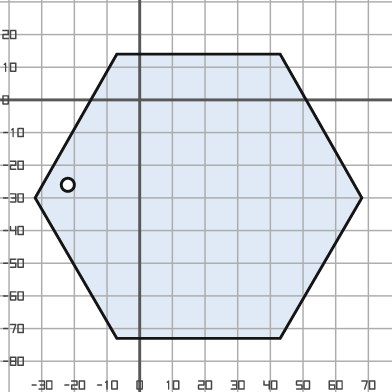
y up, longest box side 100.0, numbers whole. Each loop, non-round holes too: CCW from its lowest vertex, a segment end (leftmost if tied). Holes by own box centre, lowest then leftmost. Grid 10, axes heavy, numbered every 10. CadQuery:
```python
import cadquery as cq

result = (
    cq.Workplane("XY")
    .moveTo(-7.0, -73.0)
    .lineTo(43.0, -73.0)
    .lineTo(68.0, -30.0)
    .lineTo(43.0, 14.0)
    .lineTo(-7.0, 14.0)
    .lineTo(-32.0, -30.0)
    .close()
    .moveTo(-22.0, -26.0)
    .circle(2.0)
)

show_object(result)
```